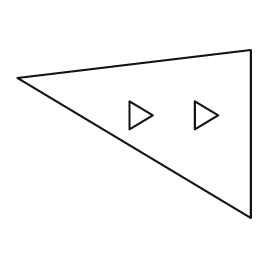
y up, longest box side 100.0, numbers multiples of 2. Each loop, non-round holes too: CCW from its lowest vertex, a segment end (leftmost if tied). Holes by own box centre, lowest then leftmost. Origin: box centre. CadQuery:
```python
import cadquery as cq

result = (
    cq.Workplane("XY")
    .moveTo(50.0, -36.0)
    .lineTo(50.0, 36.0)
    .lineTo(-50.0, 24.0)
    .close()
    .moveTo(-2.0, 2.0)
    .lineTo(8.0, 8.0)
    .lineTo(-2.0, 14.0)
    .close()
    .moveTo(26.0, 2.0)
    .lineTo(36.0, 8.0)
    .lineTo(26.0, 14.0)
    .close()
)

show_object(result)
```